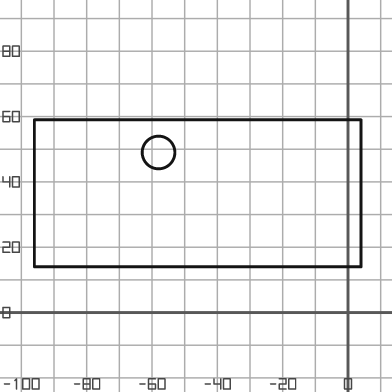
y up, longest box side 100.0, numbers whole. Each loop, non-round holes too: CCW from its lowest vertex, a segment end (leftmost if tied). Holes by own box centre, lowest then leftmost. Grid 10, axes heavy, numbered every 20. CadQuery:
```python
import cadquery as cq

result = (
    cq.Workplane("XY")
    .moveTo(-96.0, 14.0)
    .lineTo(4.0, 14.0)
    .lineTo(4.0, 59.0)
    .lineTo(-96.0, 59.0)
    .close()
    .moveTo(-58.0, 49.0)
    .circle(5.0)
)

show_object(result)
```